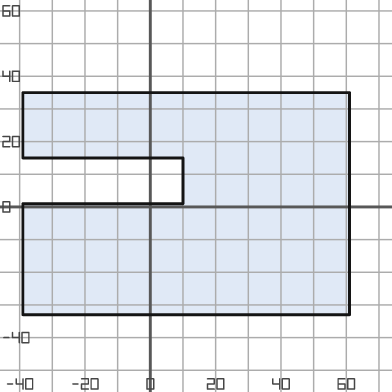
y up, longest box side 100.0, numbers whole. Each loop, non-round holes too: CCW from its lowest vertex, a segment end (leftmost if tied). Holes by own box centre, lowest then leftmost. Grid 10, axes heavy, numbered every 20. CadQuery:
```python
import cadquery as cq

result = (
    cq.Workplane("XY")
    .moveTo(-39.0, -33.0)
    .lineTo(61.0, -33.0)
    .lineTo(61.0, 35.0)
    .lineTo(-39.0, 35.0)
    .lineTo(-39.0, 15.0)
    .lineTo(10.0, 15.0)
    .lineTo(10.0, 1.0)
    .lineTo(-39.0, 1.0)
    .close()
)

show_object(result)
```